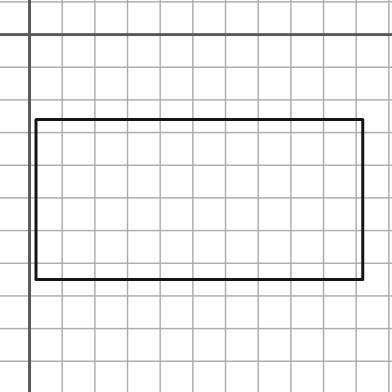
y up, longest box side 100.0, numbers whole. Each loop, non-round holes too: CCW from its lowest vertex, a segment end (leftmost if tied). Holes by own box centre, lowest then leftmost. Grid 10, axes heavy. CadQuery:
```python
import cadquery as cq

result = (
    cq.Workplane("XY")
    .moveTo(2.0, -75.0)
    .lineTo(102.0, -75.0)
    .lineTo(102.0, -26.0)
    .lineTo(2.0, -26.0)
    .close()
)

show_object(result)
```